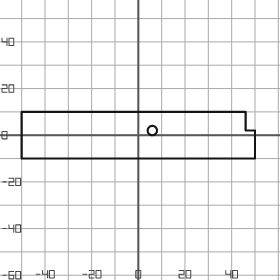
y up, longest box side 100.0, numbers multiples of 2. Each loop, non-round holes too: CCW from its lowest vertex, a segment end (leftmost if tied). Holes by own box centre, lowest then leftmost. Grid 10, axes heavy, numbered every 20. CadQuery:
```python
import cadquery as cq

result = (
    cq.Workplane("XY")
    .moveTo(-50.0, -10.0)
    .lineTo(50.0, -10.0)
    .lineTo(50.0, 2.0)
    .lineTo(46.0, 2.0)
    .lineTo(46.0, 10.0)
    .lineTo(-50.0, 10.0)
    .close()
    .moveTo(6.0, 2.0)
    .circle(2.0)
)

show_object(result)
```